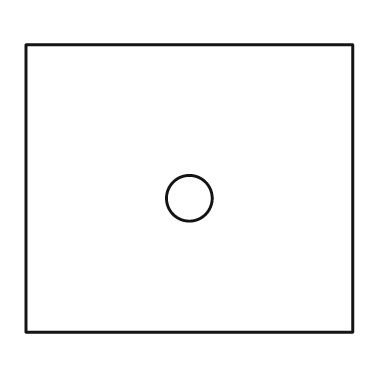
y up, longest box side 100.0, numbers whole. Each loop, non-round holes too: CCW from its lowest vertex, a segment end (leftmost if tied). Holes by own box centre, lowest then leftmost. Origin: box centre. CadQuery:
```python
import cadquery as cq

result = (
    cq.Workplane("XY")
    .moveTo(-50.0, -44.0)
    .lineTo(50.0, -44.0)
    .lineTo(50.0, 44.0)
    .lineTo(-50.0, 44.0)
    .close()
    .moveTo(0.0, -3.0)
    .circle(7.0)
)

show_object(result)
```